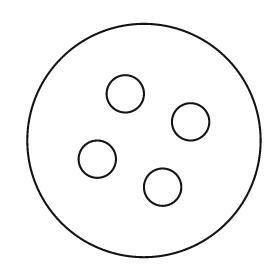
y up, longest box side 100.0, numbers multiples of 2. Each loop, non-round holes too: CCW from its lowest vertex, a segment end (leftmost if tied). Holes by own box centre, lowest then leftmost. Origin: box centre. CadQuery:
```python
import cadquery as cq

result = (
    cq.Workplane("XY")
    .moveTo(0.0, 0.0)
    .circle(50.0)
    .moveTo(8.0, -20.0)
    .circle(8.0)
    .moveTo(-20.0, -8.0)
    .circle(8.0)
    .moveTo(20.0, 8.0)
    .circle(8.0)
    .moveTo(-8.0, 20.0)
    .circle(8.0)
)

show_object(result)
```